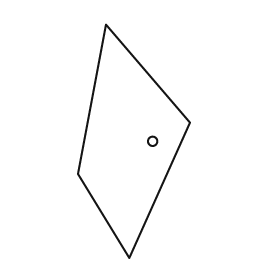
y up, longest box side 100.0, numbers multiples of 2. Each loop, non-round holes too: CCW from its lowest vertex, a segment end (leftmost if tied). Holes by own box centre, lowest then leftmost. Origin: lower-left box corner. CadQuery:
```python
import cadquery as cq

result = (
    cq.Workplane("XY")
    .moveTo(22.0, 0.0)
    .lineTo(48.0, 58.0)
    .lineTo(12.0, 100.0)
    .lineTo(0.0, 36.0)
    .close()
    .moveTo(32.0, 50.0)
    .circle(2.0)
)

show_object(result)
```